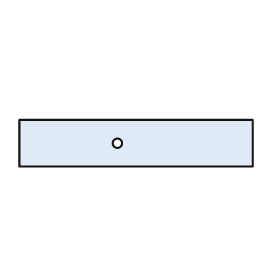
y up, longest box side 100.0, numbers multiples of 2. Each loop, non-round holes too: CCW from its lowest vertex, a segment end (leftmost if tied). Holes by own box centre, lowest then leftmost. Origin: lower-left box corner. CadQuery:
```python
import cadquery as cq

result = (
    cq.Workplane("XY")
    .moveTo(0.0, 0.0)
    .lineTo(100.0, 0.0)
    .lineTo(100.0, 20.0)
    .lineTo(0.0, 20.0)
    .close()
    .moveTo(42.0, 10.0)
    .circle(2.0)
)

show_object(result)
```